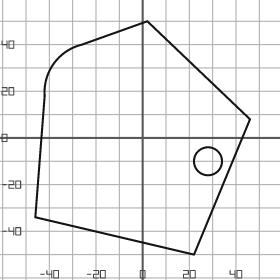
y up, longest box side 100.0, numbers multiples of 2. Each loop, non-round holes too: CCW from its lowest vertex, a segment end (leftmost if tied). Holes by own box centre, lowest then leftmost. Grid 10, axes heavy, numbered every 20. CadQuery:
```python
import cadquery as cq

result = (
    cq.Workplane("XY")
    .moveTo(22.0, -50.0)
    .lineTo(46.0, 8.0)
    .lineTo(2.0, 50.0)
    .lineTo(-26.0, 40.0)
    .threePointArc((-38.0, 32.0), (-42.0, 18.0))
    .lineTo(-46.0, -34.0)
    .close()
    .moveTo(28.0, -10.0)
    .circle(6.0)
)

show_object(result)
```